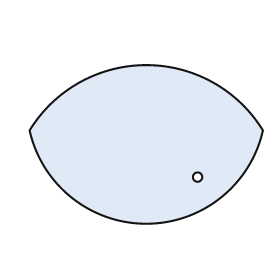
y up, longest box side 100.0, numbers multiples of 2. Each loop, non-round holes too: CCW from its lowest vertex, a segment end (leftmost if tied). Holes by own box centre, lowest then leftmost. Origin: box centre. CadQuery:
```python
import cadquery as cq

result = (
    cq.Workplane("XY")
    .moveTo(-50.0, 6.0)
    .threePointArc((0.0, -34.0), (50.0, 6.0))
    .threePointArc((0.0, 34.0), (-50.0, 6.0))
    .close()
    .moveTo(22.0, -14.0)
    .circle(2.0)
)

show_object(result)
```